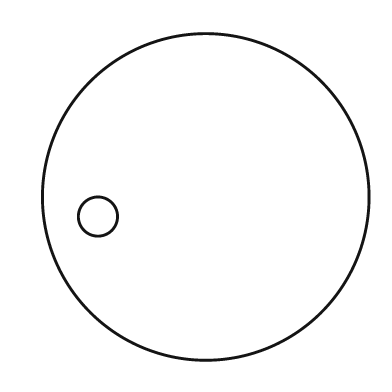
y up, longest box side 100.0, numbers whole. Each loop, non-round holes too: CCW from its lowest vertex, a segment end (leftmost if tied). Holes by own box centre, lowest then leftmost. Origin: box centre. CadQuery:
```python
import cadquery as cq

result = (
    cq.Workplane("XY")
    .moveTo(0.0, 0.0)
    .circle(50.0)
    .moveTo(-33.0, -6.0)
    .circle(6.0)
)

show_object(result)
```